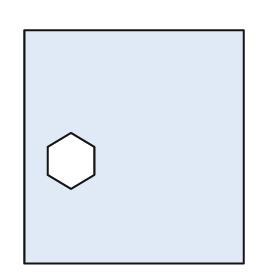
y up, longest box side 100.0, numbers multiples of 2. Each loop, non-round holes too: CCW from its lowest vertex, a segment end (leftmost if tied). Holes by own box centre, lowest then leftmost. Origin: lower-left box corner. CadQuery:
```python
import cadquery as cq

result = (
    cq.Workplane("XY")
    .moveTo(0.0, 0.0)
    .lineTo(94.0, 0.0)
    .lineTo(94.0, 100.0)
    .lineTo(0.0, 100.0)
    .close()
    .moveTo(20.0, 32.0)
    .lineTo(30.0, 38.0)
    .lineTo(30.0, 50.0)
    .lineTo(20.0, 56.0)
    .lineTo(10.0, 50.0)
    .lineTo(10.0, 38.0)
    .close()
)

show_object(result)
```